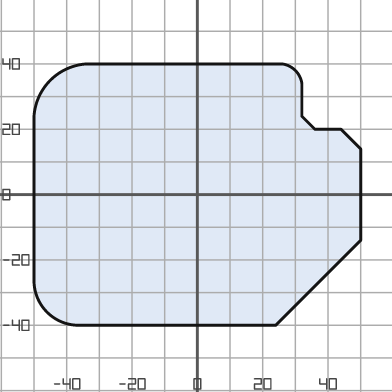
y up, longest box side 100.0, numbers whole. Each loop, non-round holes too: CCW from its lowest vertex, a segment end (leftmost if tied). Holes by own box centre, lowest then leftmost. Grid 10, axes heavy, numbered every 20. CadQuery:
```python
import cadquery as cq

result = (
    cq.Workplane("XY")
    .moveTo(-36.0, -40.0)
    .lineTo(24.0, -40.0)
    .lineTo(50.0, -14.0)
    .lineTo(50.0, 14.0)
    .lineTo(44.0, 20.0)
    .lineTo(36.0, 20.0)
    .lineTo(32.0, 24.0)
    .lineTo(32.0, 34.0)
    .threePointArc((30.0, 38.0), (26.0, 40.0))
    .lineTo(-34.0, 40.0)
    .threePointArc((-45.0, 35.0), (-50.0, 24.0))
    .lineTo(-50.0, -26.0)
    .threePointArc((-46.0, -36.0), (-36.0, -40.0))
    .close()
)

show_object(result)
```